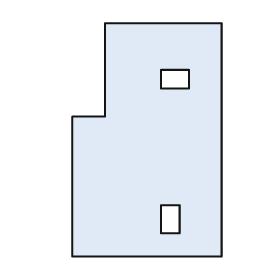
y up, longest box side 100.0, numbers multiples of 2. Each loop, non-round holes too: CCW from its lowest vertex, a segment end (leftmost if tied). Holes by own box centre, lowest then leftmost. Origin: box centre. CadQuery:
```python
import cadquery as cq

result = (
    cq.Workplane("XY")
    .moveTo(-32.0, -50.0)
    .lineTo(32.0, -50.0)
    .lineTo(32.0, 50.0)
    .lineTo(-18.0, 50.0)
    .lineTo(-18.0, 10.0)
    .lineTo(-32.0, 10.0)
    .close()
    .moveTo(6.0, -40.0)
    .lineTo(14.0, -40.0)
    .lineTo(14.0, -28.0)
    .lineTo(6.0, -28.0)
    .close()
    .moveTo(6.0, 22.0)
    .lineTo(18.0, 22.0)
    .lineTo(18.0, 30.0)
    .lineTo(6.0, 30.0)
    .close()
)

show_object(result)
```